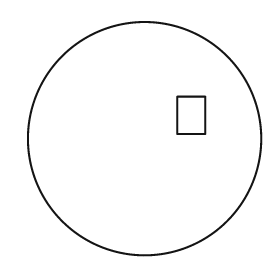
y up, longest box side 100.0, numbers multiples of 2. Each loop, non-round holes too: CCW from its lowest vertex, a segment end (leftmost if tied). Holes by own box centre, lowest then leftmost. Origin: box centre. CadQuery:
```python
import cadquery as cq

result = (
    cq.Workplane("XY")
    .moveTo(0.0, 0.0)
    .circle(50.0)
    .moveTo(14.0, 2.0)
    .lineTo(26.0, 2.0)
    .lineTo(26.0, 18.0)
    .lineTo(14.0, 18.0)
    .close()
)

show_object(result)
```